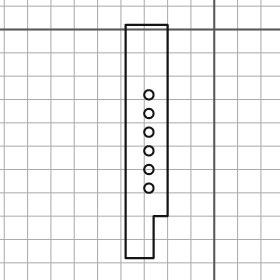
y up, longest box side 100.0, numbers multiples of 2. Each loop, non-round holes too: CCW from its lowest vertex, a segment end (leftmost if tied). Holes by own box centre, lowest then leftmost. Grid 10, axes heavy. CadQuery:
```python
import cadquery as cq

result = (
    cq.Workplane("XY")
    .moveTo(-38.0, -98.0)
    .lineTo(-26.0, -98.0)
    .lineTo(-26.0, -80.0)
    .lineTo(-20.0, -80.0)
    .lineTo(-20.0, 2.0)
    .lineTo(-38.0, 2.0)
    .close()
    .moveTo(-28.0, -68.0)
    .circle(2.0)
    .moveTo(-28.0, -60.0)
    .circle(2.0)
    .moveTo(-28.0, -52.0)
    .circle(2.0)
    .moveTo(-28.0, -44.0)
    .circle(2.0)
    .moveTo(-28.0, -36.0)
    .circle(2.0)
    .moveTo(-28.0, -28.0)
    .circle(2.0)
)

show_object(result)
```